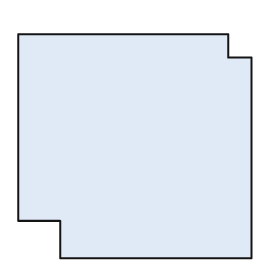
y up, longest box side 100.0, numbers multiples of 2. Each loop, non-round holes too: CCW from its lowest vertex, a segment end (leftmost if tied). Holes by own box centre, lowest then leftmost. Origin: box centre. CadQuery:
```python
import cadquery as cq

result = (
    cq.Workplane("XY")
    .moveTo(-32.0, -48.0)
    .lineTo(50.0, -48.0)
    .lineTo(50.0, 38.0)
    .lineTo(40.0, 38.0)
    .lineTo(40.0, 48.0)
    .lineTo(-50.0, 48.0)
    .lineTo(-50.0, -32.0)
    .lineTo(-32.0, -32.0)
    .close()
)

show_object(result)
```